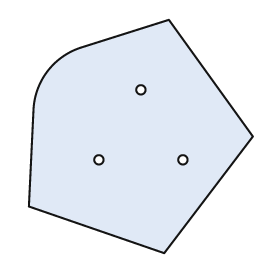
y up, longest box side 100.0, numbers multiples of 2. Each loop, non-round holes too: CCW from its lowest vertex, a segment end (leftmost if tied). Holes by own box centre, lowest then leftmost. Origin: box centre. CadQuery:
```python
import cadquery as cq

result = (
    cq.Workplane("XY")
    .moveTo(10.0, -50.0)
    .lineTo(48.0, 0.0)
    .lineTo(12.0, 50.0)
    .lineTo(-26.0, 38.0)
    .threePointArc((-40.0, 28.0), (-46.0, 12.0))
    .lineTo(-48.0, -30.0)
    .close()
    .moveTo(-18.0, -10.0)
    .circle(2.0)
    .moveTo(18.0, -10.0)
    .circle(2.0)
    .moveTo(0.0, 20.0)
    .circle(2.0)
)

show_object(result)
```